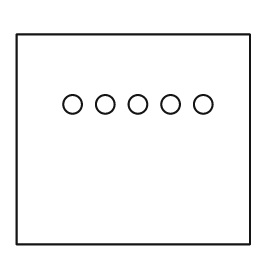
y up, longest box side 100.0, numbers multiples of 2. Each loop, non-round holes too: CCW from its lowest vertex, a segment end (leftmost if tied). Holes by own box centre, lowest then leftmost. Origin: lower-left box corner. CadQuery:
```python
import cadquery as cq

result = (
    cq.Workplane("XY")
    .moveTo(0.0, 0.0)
    .lineTo(100.0, 0.0)
    .lineTo(100.0, 90.0)
    .lineTo(0.0, 90.0)
    .close()
    .moveTo(24.0, 60.0)
    .circle(4.0)
    .moveTo(38.0, 60.0)
    .circle(4.0)
    .moveTo(52.0, 60.0)
    .circle(4.0)
    .moveTo(66.0, 60.0)
    .circle(4.0)
    .moveTo(80.0, 60.0)
    .circle(4.0)
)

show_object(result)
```